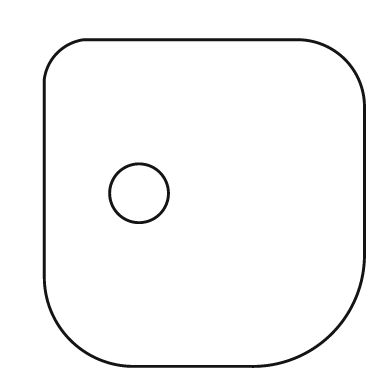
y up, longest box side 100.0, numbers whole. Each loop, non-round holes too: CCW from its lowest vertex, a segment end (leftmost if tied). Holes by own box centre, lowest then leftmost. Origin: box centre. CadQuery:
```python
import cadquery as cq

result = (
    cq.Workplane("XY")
    .moveTo(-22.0, -50.0)
    .lineTo(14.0, -50.0)
    .threePointArc((39.0, -40.0), (49.0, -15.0))
    .lineTo(49.0, 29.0)
    .threePointArc((43.0, 44.0), (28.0, 50.0))
    .lineTo(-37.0, 50.0)
    .threePointArc((-45.0, 46.0), (-49.0, 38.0))
    .lineTo(-49.0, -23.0)
    .threePointArc((-41.0, -42.0), (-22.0, -50.0))
    .close()
    .moveTo(-20.0, 3.0)
    .circle(9.0)
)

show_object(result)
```